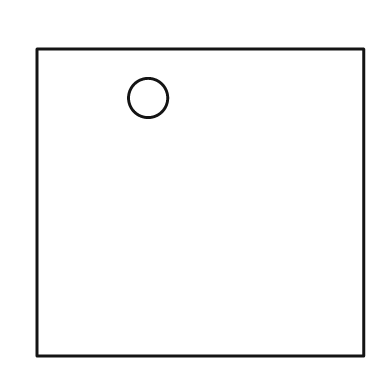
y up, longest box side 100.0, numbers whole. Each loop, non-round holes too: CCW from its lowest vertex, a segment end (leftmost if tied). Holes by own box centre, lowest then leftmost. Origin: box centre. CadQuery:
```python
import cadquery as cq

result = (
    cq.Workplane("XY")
    .moveTo(-50.0, -47.0)
    .lineTo(50.0, -47.0)
    .lineTo(50.0, 47.0)
    .lineTo(-50.0, 47.0)
    .close()
    .moveTo(-16.0, 32.0)
    .circle(6.0)
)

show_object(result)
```